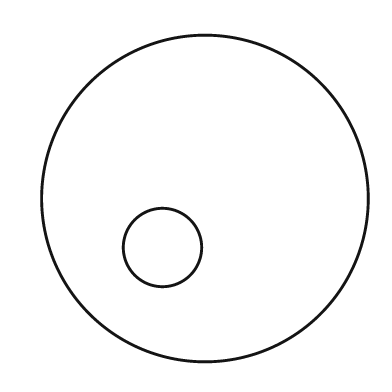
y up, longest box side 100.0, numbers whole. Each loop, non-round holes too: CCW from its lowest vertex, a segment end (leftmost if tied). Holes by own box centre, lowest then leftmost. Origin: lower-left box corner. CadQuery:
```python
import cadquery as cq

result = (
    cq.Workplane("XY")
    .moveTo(50.0, 50.0)
    .circle(50.0)
    .moveTo(37.0, 35.0)
    .circle(12.0)
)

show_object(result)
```